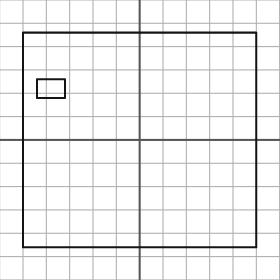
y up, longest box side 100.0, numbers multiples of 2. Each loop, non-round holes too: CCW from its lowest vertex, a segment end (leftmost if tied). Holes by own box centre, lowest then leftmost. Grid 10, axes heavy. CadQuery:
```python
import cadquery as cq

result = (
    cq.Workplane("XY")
    .moveTo(-50.0, -46.0)
    .lineTo(50.0, -46.0)
    .lineTo(50.0, 46.0)
    .lineTo(-50.0, 46.0)
    .close()
    .moveTo(-44.0, 18.0)
    .lineTo(-32.0, 18.0)
    .lineTo(-32.0, 26.0)
    .lineTo(-44.0, 26.0)
    .close()
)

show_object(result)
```